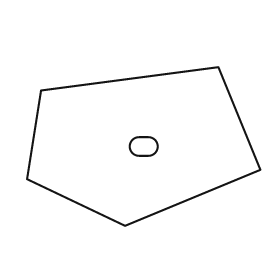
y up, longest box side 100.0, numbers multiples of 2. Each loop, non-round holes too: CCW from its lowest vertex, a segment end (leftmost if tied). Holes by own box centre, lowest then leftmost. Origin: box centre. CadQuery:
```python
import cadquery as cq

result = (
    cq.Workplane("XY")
    .moveTo(-8.0, -34.0)
    .lineTo(50.0, -10.0)
    .lineTo(32.0, 34.0)
    .lineTo(-44.0, 24.0)
    .lineTo(-50.0, -14.0)
    .close()
    .moveTo(-2.0, -4.0)
    .lineTo(2.0, -4.0)
    .threePointArc((6.0, 0.0), (2.0, 4.0))
    .lineTo(-2.0, 4.0)
    .threePointArc((-6.0, 0.0), (-2.0, -4.0))
    .close()
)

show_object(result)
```